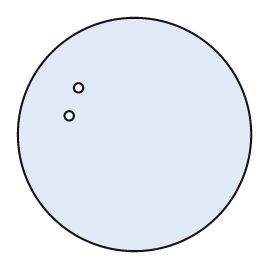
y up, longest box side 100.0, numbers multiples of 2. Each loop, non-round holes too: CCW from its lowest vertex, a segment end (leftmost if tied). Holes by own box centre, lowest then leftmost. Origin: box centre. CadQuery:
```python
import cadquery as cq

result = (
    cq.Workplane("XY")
    .moveTo(0.0, 0.0)
    .circle(50.0)
    .moveTo(-28.0, 8.0)
    .circle(2.0)
    .moveTo(-24.0, 20.0)
    .circle(2.0)
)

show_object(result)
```